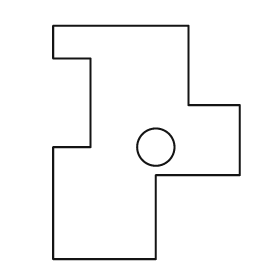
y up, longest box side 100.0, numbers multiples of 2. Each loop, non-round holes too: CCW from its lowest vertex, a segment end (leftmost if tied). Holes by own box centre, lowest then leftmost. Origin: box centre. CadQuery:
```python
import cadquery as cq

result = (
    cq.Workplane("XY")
    .moveTo(-40.0, -50.0)
    .lineTo(4.0, -50.0)
    .lineTo(4.0, -14.0)
    .lineTo(40.0, -14.0)
    .lineTo(40.0, 16.0)
    .lineTo(18.0, 16.0)
    .lineTo(18.0, 50.0)
    .lineTo(-40.0, 50.0)
    .lineTo(-40.0, 36.0)
    .lineTo(-24.0, 36.0)
    .lineTo(-24.0, -2.0)
    .lineTo(-40.0, -2.0)
    .close()
    .moveTo(4.0, -2.0)
    .circle(8.0)
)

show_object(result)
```